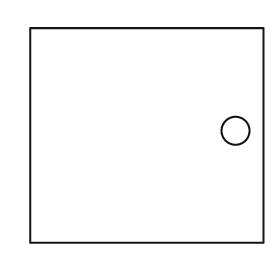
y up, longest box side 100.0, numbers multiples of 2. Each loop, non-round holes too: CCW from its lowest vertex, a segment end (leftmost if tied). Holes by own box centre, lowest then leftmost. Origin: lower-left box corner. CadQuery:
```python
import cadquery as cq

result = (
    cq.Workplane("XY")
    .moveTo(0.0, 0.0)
    .lineTo(100.0, 0.0)
    .lineTo(100.0, 92.0)
    .lineTo(0.0, 92.0)
    .close()
    .moveTo(88.0, 48.0)
    .circle(6.0)
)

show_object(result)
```